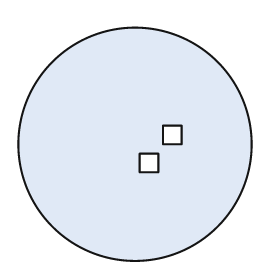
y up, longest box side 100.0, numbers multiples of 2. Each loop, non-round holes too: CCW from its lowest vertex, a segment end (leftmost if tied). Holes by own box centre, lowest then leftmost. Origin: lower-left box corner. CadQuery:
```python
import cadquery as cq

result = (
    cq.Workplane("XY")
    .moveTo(50.0, 50.0)
    .circle(50.0)
    .moveTo(52.0, 38.0)
    .lineTo(60.0, 38.0)
    .lineTo(60.0, 46.0)
    .lineTo(52.0, 46.0)
    .close()
    .moveTo(62.0, 50.0)
    .lineTo(70.0, 50.0)
    .lineTo(70.0, 58.0)
    .lineTo(62.0, 58.0)
    .close()
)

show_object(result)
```